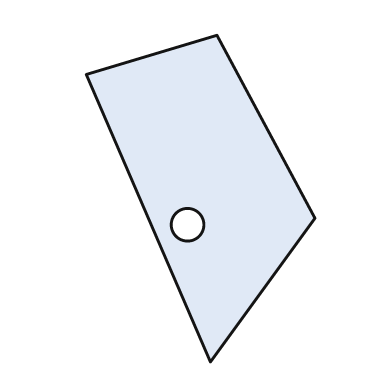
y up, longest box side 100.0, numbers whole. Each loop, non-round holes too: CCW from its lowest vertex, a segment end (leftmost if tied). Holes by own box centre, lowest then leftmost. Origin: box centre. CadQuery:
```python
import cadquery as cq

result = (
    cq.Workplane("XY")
    .moveTo(3.0, -50.0)
    .lineTo(35.0, -6.0)
    .lineTo(5.0, 50.0)
    .lineTo(-35.0, 38.0)
    .close()
    .moveTo(-4.0, -8.0)
    .circle(5.0)
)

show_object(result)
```